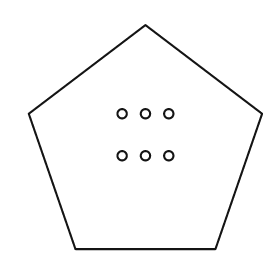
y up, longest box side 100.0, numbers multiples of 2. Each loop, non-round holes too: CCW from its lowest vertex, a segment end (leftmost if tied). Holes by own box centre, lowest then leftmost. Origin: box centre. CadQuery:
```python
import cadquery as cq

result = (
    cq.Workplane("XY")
    .moveTo(-30.0, -48.0)
    .lineTo(30.0, -48.0)
    .lineTo(50.0, 10.0)
    .lineTo(0.0, 48.0)
    .lineTo(-50.0, 10.0)
    .close()
    .moveTo(-10.0, -8.0)
    .circle(2.0)
    .moveTo(0.0, -8.0)
    .circle(2.0)
    .moveTo(10.0, -8.0)
    .circle(2.0)
    .moveTo(-10.0, 10.0)
    .circle(2.0)
    .moveTo(0.0, 10.0)
    .circle(2.0)
    .moveTo(10.0, 10.0)
    .circle(2.0)
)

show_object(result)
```